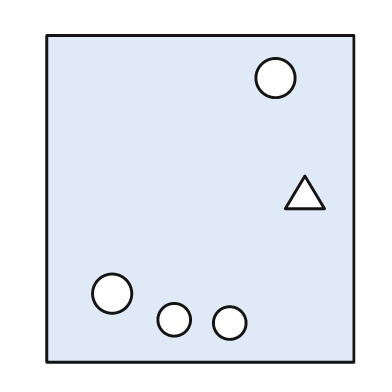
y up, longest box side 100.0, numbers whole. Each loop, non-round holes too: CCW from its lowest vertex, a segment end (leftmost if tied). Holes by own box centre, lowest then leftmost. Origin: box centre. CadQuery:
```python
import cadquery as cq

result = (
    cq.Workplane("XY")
    .moveTo(-47.0, -50.0)
    .lineTo(47.0, -50.0)
    .lineTo(47.0, 50.0)
    .lineTo(-47.0, 50.0)
    .close()
    .moveTo(9.0, -38.0)
    .circle(5.0)
    .moveTo(-8.0, -37.0)
    .circle(5.0)
    .moveTo(-27.0, -29.0)
    .circle(6.0)
    .moveTo(26.0, -3.0)
    .lineTo(38.0, -3.0)
    .lineTo(32.0, 7.0)
    .close()
    .moveTo(23.0, 37.0)
    .circle(6.0)
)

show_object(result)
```